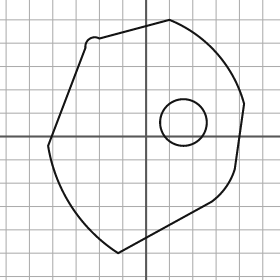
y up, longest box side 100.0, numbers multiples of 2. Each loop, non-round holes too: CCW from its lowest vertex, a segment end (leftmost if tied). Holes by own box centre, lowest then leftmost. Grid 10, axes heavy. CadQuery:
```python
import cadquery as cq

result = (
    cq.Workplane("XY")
    .moveTo(-12.0, -50.0)
    .lineTo(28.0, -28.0)
    .threePointArc((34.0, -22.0), (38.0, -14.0))
    .lineTo(42.0, 14.0)
    .threePointArc((30.0, 36.0), (10.0, 50.0))
    .lineTo(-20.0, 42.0)
    .threePointArc((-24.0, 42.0), (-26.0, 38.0))
    .lineTo(-42.0, -4.0)
    .threePointArc((-32.0, -30.0), (-12.0, -50.0))
    .close()
    .moveTo(16.0, 6.0)
    .circle(10.0)
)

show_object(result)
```